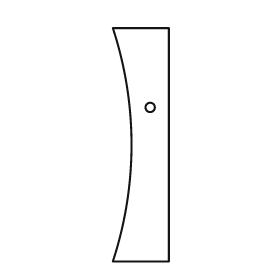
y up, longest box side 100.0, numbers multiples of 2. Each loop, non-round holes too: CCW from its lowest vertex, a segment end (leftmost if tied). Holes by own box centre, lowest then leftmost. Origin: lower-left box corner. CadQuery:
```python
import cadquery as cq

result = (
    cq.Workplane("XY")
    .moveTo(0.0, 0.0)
    .lineTo(24.0, 0.0)
    .lineTo(24.0, 100.0)
    .lineTo(0.0, 100.0)
    .threePointArc((8.0, 50.0), (0.0, 0.0))
    .close()
    .moveTo(16.0, 66.0)
    .circle(2.0)
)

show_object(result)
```